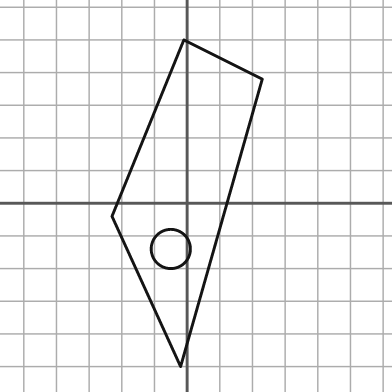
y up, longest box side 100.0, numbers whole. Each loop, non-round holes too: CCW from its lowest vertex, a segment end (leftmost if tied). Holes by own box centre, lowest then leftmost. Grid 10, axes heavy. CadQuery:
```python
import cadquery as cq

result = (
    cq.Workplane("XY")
    .moveTo(-2.0, -50.0)
    .lineTo(23.0, 38.0)
    .lineTo(-1.0, 50.0)
    .lineTo(-23.0, -4.0)
    .close()
    .moveTo(-5.0, -14.0)
    .circle(6.0)
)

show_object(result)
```